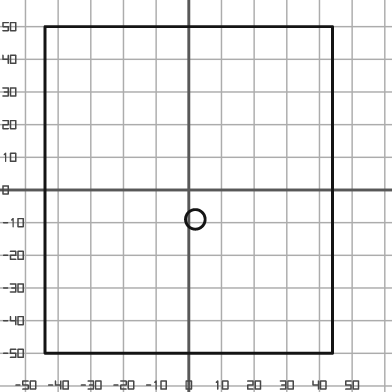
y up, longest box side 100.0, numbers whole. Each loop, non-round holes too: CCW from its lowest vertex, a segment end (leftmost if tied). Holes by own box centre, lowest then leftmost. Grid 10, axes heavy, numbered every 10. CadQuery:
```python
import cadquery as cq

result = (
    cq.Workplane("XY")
    .moveTo(-44.0, -50.0)
    .lineTo(44.0, -50.0)
    .lineTo(44.0, 50.0)
    .lineTo(-44.0, 50.0)
    .close()
    .moveTo(2.0, -9.0)
    .circle(3.0)
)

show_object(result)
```